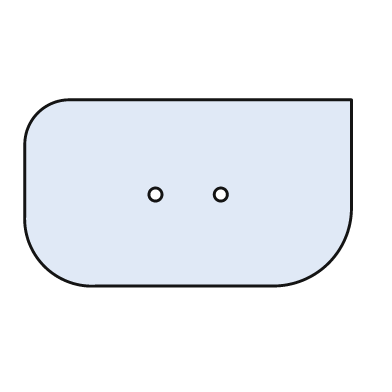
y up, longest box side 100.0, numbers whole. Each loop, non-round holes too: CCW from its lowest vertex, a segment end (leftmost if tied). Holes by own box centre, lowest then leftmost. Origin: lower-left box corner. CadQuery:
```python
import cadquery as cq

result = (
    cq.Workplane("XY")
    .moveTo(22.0, 0.0)
    .lineTo(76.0, 0.0)
    .threePointArc((93.0, 7.0), (100.0, 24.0))
    .lineTo(100.0, 57.0)
    .lineTo(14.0, 57.0)
    .threePointArc((4.0, 53.0), (0.0, 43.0))
    .lineTo(0.0, 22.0)
    .threePointArc((6.0, 6.0), (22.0, 0.0))
    .close()
    .moveTo(40.0, 28.0)
    .circle(2.0)
    .moveTo(60.0, 28.0)
    .circle(2.0)
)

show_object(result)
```